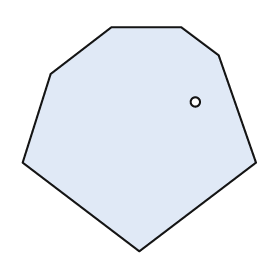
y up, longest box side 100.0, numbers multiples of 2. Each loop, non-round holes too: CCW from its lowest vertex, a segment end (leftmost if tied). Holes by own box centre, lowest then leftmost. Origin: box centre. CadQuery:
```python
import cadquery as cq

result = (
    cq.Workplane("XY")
    .moveTo(0.0, -48.0)
    .lineTo(50.0, -10.0)
    .lineTo(34.0, 36.0)
    .lineTo(18.0, 48.0)
    .lineTo(-12.0, 48.0)
    .lineTo(-38.0, 28.0)
    .lineTo(-50.0, -10.0)
    .close()
    .moveTo(24.0, 16.0)
    .circle(2.0)
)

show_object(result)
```